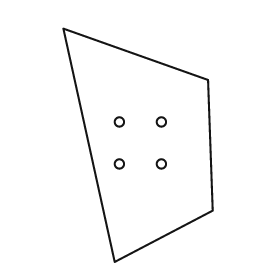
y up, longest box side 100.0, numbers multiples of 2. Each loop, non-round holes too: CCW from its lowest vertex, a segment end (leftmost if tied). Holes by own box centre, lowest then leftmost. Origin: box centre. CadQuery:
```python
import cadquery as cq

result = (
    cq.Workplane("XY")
    .moveTo(-10.0, -50.0)
    .lineTo(32.0, -28.0)
    .lineTo(30.0, 28.0)
    .lineTo(-32.0, 50.0)
    .close()
    .moveTo(-8.0, -8.0)
    .circle(2.0)
    .moveTo(10.0, -8.0)
    .circle(2.0)
    .moveTo(-8.0, 10.0)
    .circle(2.0)
    .moveTo(10.0, 10.0)
    .circle(2.0)
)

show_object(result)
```